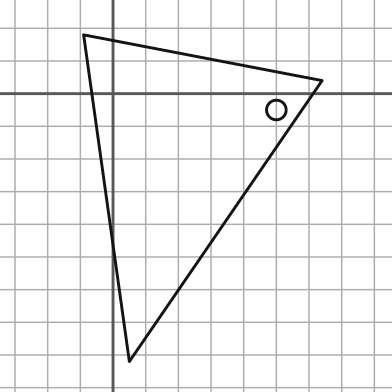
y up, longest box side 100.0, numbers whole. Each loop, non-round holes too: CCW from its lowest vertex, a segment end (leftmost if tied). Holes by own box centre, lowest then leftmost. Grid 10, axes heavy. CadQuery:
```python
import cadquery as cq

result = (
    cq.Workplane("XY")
    .moveTo(5.0, -82.0)
    .lineTo(64.0, 4.0)
    .lineTo(-9.0, 18.0)
    .close()
    .moveTo(50.0, -5.0)
    .circle(3.0)
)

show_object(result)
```